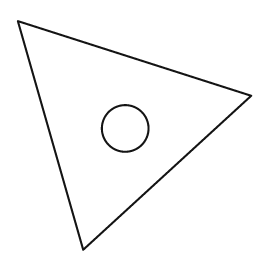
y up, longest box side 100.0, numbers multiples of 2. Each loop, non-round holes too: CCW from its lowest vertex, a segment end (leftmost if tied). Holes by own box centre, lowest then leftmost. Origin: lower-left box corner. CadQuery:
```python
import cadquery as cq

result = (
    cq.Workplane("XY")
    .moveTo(28.0, 0.0)
    .lineTo(100.0, 66.0)
    .lineTo(0.0, 98.0)
    .close()
    .moveTo(46.0, 52.0)
    .circle(10.0)
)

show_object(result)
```